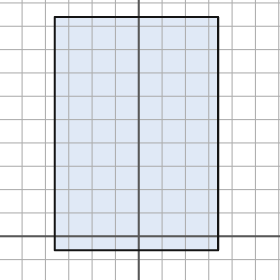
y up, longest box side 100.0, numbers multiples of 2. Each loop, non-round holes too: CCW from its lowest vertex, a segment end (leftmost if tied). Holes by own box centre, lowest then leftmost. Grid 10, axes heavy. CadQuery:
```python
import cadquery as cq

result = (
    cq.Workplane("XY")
    .moveTo(-36.0, -6.0)
    .lineTo(34.0, -6.0)
    .lineTo(34.0, 94.0)
    .lineTo(-36.0, 94.0)
    .close()
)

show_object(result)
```